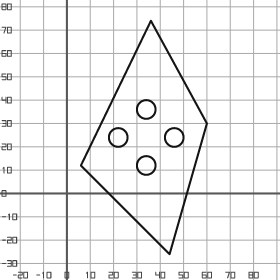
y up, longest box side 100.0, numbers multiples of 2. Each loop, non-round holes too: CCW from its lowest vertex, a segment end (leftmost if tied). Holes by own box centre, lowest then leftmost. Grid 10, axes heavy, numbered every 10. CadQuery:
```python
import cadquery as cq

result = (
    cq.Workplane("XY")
    .moveTo(44.0, -26.0)
    .lineTo(60.0, 30.0)
    .lineTo(36.0, 74.0)
    .lineTo(6.0, 12.0)
    .close()
    .moveTo(34.0, 12.0)
    .circle(4.0)
    .moveTo(22.0, 24.0)
    .circle(4.0)
    .moveTo(46.0, 24.0)
    .circle(4.0)
    .moveTo(34.0, 36.0)
    .circle(4.0)
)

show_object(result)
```